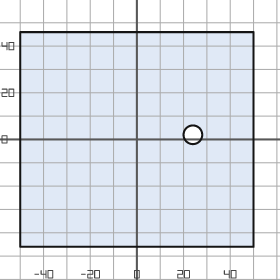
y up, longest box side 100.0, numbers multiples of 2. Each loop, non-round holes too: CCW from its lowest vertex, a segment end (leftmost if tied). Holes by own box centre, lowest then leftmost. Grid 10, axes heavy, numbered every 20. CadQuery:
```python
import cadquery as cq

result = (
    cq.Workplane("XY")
    .moveTo(-50.0, -46.0)
    .lineTo(50.0, -46.0)
    .lineTo(50.0, 46.0)
    .lineTo(-50.0, 46.0)
    .close()
    .moveTo(24.0, 2.0)
    .circle(4.0)
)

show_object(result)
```